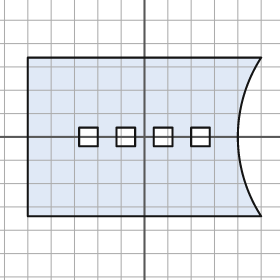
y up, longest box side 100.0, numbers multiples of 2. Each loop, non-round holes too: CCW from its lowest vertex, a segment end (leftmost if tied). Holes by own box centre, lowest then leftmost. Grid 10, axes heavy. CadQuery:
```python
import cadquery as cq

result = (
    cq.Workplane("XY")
    .moveTo(-50.0, -34.0)
    .lineTo(50.0, -34.0)
    .threePointArc((40.0, 0.0), (50.0, 34.0))
    .lineTo(-50.0, 34.0)
    .close()
    .moveTo(-28.0, -4.0)
    .lineTo(-20.0, -4.0)
    .lineTo(-20.0, 4.0)
    .lineTo(-28.0, 4.0)
    .close()
    .moveTo(-12.0, -4.0)
    .lineTo(-4.0, -4.0)
    .lineTo(-4.0, 4.0)
    .lineTo(-12.0, 4.0)
    .close()
    .moveTo(4.0, -4.0)
    .lineTo(12.0, -4.0)
    .lineTo(12.0, 4.0)
    .lineTo(4.0, 4.0)
    .close()
    .moveTo(20.0, -4.0)
    .lineTo(28.0, -4.0)
    .lineTo(28.0, 4.0)
    .lineTo(20.0, 4.0)
    .close()
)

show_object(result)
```